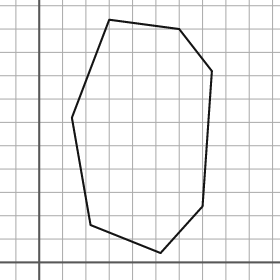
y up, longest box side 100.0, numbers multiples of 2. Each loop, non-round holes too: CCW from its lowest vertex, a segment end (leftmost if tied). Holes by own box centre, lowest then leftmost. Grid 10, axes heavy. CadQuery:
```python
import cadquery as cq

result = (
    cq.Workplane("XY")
    .moveTo(52.0, 4.0)
    .lineTo(70.0, 24.0)
    .lineTo(74.0, 82.0)
    .lineTo(60.0, 100.0)
    .lineTo(30.0, 104.0)
    .lineTo(14.0, 62.0)
    .lineTo(22.0, 16.0)
    .close()
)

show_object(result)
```